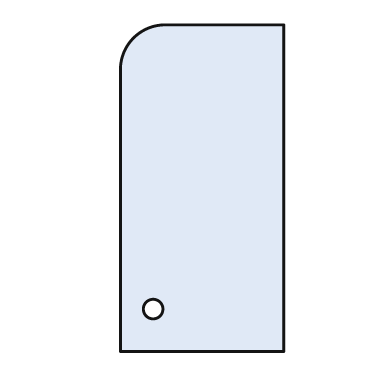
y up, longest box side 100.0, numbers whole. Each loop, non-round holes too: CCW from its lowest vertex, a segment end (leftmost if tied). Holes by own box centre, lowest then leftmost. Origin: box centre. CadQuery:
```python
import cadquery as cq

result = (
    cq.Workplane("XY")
    .moveTo(-25.0, -50.0)
    .lineTo(25.0, -50.0)
    .lineTo(25.0, 50.0)
    .lineTo(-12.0, 50.0)
    .threePointArc((-21.0, 46.0), (-25.0, 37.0))
    .close()
    .moveTo(-15.0, -37.0)
    .circle(3.0)
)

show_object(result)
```